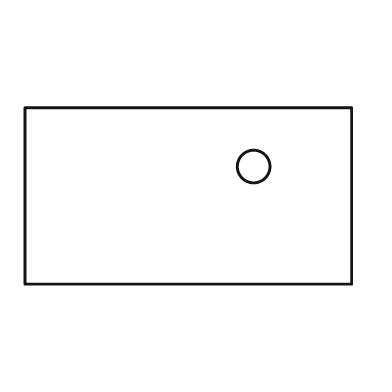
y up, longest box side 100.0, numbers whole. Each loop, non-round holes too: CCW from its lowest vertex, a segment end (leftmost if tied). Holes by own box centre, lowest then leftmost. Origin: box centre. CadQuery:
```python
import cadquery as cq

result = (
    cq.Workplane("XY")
    .moveTo(-50.0, -27.0)
    .lineTo(50.0, -27.0)
    .lineTo(50.0, 27.0)
    .lineTo(-50.0, 27.0)
    .close()
    .moveTo(20.0, 9.0)
    .circle(5.0)
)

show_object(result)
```